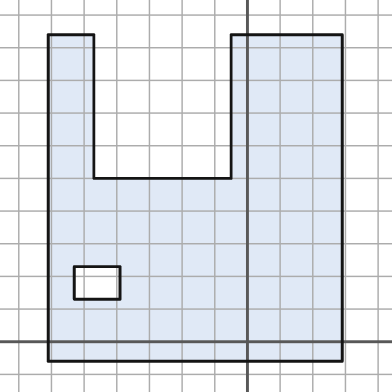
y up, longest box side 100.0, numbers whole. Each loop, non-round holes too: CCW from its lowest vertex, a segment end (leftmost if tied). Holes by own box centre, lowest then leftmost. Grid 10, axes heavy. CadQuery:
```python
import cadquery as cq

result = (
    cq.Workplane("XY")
    .moveTo(-61.0, -6.0)
    .lineTo(29.0, -6.0)
    .lineTo(29.0, 94.0)
    .lineTo(-5.0, 94.0)
    .lineTo(-5.0, 50.0)
    .lineTo(-47.0, 50.0)
    .lineTo(-47.0, 94.0)
    .lineTo(-61.0, 94.0)
    .close()
    .moveTo(-53.0, 13.0)
    .lineTo(-39.0, 13.0)
    .lineTo(-39.0, 23.0)
    .lineTo(-53.0, 23.0)
    .close()
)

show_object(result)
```